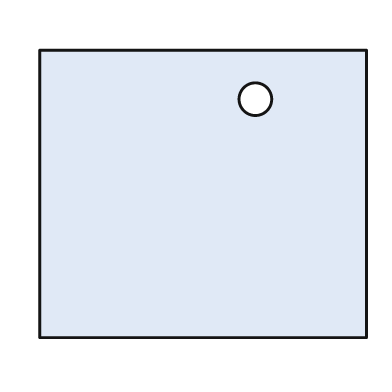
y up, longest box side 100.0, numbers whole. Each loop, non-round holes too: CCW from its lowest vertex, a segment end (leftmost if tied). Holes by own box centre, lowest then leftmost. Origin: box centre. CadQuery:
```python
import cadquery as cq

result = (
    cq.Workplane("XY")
    .moveTo(-50.0, -44.0)
    .lineTo(50.0, -44.0)
    .lineTo(50.0, 44.0)
    .lineTo(-50.0, 44.0)
    .close()
    .moveTo(16.0, 29.0)
    .circle(5.0)
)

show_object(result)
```